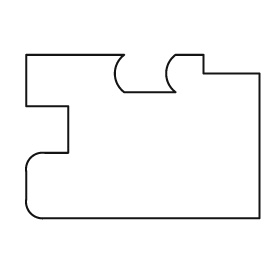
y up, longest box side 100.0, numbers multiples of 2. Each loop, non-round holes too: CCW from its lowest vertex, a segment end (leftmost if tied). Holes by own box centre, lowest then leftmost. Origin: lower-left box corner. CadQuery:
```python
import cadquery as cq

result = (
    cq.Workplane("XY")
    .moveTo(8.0, 0.0)
    .lineTo(100.0, 0.0)
    .lineTo(100.0, 62.0)
    .lineTo(76.0, 62.0)
    .lineTo(76.0, 70.0)
    .lineTo(64.0, 70.0)
    .threePointArc((60.0, 62.0), (64.0, 54.0))
    .lineTo(42.0, 54.0)
    .threePointArc((38.0, 62.0), (42.0, 70.0))
    .lineTo(0.0, 70.0)
    .lineTo(0.0, 48.0)
    .lineTo(18.0, 48.0)
    .lineTo(18.0, 28.0)
    .lineTo(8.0, 28.0)
    .threePointArc((2.0, 26.0), (0.0, 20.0))
    .lineTo(0.0, 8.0)
    .threePointArc((2.0, 2.0), (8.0, 0.0))
    .close()
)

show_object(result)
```